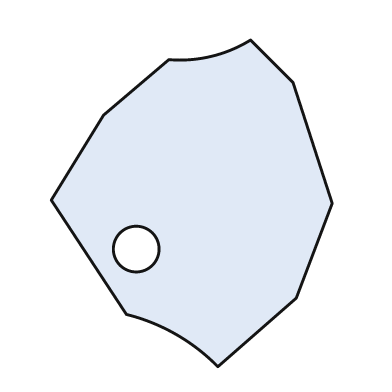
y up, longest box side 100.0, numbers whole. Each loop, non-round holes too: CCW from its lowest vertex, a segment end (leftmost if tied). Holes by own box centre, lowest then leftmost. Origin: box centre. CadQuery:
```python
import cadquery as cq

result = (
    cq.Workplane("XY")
    .moveTo(8.0, -50.0)
    .lineTo(32.0, -29.0)
    .lineTo(43.0, 0.0)
    .lineTo(31.0, 37.0)
    .lineTo(18.0, 50.0)
    .threePointArc((6.0, 45.0), (-7.0, 44.0))
    .lineTo(-27.0, 27.0)
    .lineTo(-43.0, 1.0)
    .lineTo(-20.0, -34.0)
    .threePointArc((-5.0, -40.0), (8.0, -50.0))
    .close()
    .moveTo(-17.0, -14.0)
    .circle(7.0)
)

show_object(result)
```